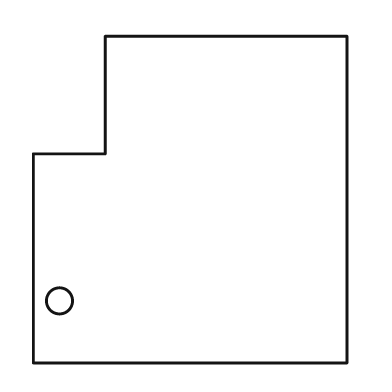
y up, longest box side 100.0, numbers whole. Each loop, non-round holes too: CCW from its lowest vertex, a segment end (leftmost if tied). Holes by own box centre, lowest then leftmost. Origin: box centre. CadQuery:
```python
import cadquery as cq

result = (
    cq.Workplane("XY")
    .moveTo(-48.0, -50.0)
    .lineTo(48.0, -50.0)
    .lineTo(48.0, 50.0)
    .lineTo(-26.0, 50.0)
    .lineTo(-26.0, 14.0)
    .lineTo(-48.0, 14.0)
    .close()
    .moveTo(-40.0, -31.0)
    .circle(4.0)
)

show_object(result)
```